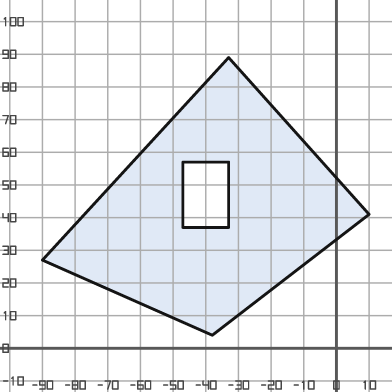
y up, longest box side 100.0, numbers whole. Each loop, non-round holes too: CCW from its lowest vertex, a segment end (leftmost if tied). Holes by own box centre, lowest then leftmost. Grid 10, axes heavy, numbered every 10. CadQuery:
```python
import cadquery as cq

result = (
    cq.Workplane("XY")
    .moveTo(-38.0, 4.0)
    .lineTo(10.0, 41.0)
    .lineTo(-33.0, 89.0)
    .lineTo(-90.0, 27.0)
    .close()
    .moveTo(-47.0, 37.0)
    .lineTo(-33.0, 37.0)
    .lineTo(-33.0, 57.0)
    .lineTo(-47.0, 57.0)
    .close()
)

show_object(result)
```